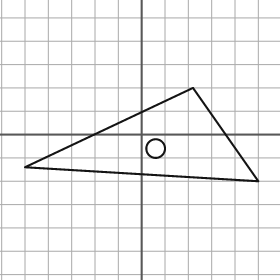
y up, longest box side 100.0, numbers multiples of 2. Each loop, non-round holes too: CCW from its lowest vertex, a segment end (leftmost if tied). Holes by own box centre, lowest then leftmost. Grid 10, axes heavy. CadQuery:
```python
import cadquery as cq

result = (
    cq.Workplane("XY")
    .moveTo(50.0, -20.0)
    .lineTo(22.0, 20.0)
    .lineTo(-50.0, -14.0)
    .close()
    .moveTo(6.0, -6.0)
    .circle(4.0)
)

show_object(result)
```